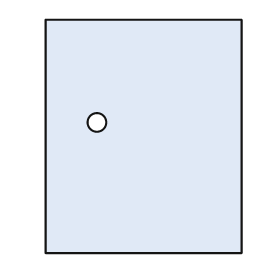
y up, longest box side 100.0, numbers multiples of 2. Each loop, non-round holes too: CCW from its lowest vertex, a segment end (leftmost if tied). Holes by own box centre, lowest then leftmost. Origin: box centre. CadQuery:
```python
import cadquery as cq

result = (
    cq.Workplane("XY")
    .moveTo(-42.0, -50.0)
    .lineTo(42.0, -50.0)
    .lineTo(42.0, 50.0)
    .lineTo(-42.0, 50.0)
    .close()
    .moveTo(-20.0, 6.0)
    .circle(4.0)
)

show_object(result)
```